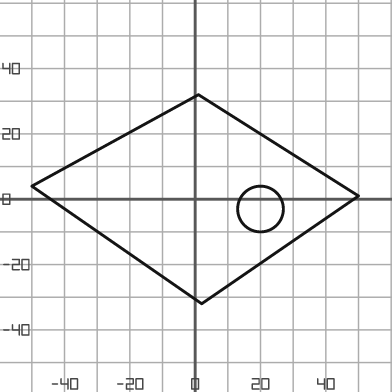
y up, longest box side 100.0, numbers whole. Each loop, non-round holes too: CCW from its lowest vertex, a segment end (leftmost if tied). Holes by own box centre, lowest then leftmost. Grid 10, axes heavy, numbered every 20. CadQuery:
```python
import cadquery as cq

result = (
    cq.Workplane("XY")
    .moveTo(2.0, -32.0)
    .lineTo(50.0, 1.0)
    .lineTo(1.0, 32.0)
    .lineTo(-50.0, 4.0)
    .close()
    .moveTo(20.0, -3.0)
    .circle(7.0)
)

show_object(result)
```